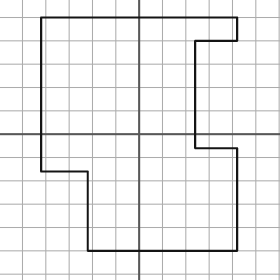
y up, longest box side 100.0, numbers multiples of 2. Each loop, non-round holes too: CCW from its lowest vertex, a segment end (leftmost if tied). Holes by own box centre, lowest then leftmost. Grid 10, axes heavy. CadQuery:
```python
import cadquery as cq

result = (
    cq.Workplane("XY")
    .moveTo(-22.0, -50.0)
    .lineTo(42.0, -50.0)
    .lineTo(42.0, -6.0)
    .lineTo(24.0, -6.0)
    .lineTo(24.0, 40.0)
    .lineTo(42.0, 40.0)
    .lineTo(42.0, 50.0)
    .lineTo(-42.0, 50.0)
    .lineTo(-42.0, -16.0)
    .lineTo(-22.0, -16.0)
    .close()
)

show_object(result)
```